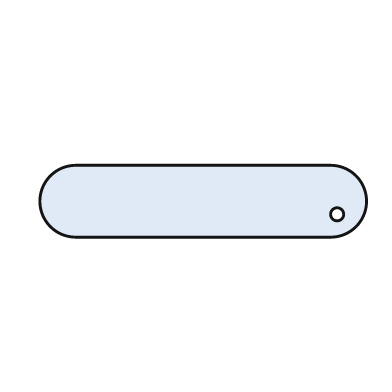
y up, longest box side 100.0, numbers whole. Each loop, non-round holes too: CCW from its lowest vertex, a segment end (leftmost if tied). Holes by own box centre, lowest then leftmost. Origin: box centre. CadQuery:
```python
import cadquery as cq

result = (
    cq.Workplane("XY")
    .moveTo(-39.0, -11.0)
    .lineTo(39.0, -11.0)
    .threePointArc((50.0, 0.0), (39.0, 11.0))
    .lineTo(-39.0, 11.0)
    .threePointArc((-50.0, 0.0), (-39.0, -11.0))
    .close()
    .moveTo(41.0, -4.0)
    .circle(2.0)
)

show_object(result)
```